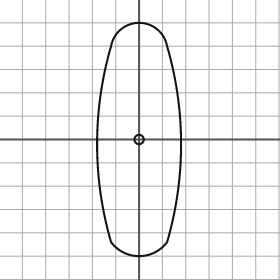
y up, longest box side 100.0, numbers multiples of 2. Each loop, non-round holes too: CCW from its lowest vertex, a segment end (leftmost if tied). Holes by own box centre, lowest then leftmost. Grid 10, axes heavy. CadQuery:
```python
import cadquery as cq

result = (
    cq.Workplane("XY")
    .moveTo(-12.0, -44.0)
    .threePointArc((0.0, -50.0), (12.0, -44.0))
    .threePointArc((18.0, -2.0), (12.0, 40.0))
    .threePointArc((0.0, 50.0), (-12.0, 40.0))
    .threePointArc((-18.0, -2.0), (-12.0, -44.0))
    .close()
    .moveTo(0.0, 0.0)
    .circle(2.0)
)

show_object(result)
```